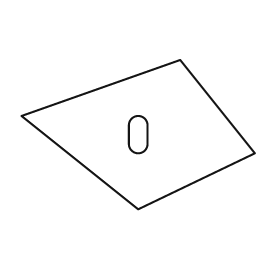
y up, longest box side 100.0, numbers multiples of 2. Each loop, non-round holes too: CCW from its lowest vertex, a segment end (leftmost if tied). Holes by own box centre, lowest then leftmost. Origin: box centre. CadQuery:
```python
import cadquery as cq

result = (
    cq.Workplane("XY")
    .moveTo(0.0, -32.0)
    .lineTo(50.0, -8.0)
    .lineTo(18.0, 32.0)
    .lineTo(-50.0, 8.0)
    .close()
    .moveTo(-4.0, -4.0)
    .threePointArc((0.0, -8.0), (4.0, -4.0))
    .lineTo(4.0, 4.0)
    .threePointArc((0.0, 8.0), (-4.0, 4.0))
    .close()
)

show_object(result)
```